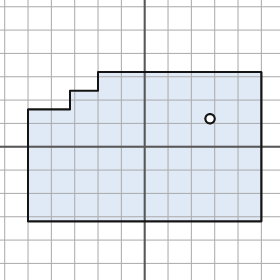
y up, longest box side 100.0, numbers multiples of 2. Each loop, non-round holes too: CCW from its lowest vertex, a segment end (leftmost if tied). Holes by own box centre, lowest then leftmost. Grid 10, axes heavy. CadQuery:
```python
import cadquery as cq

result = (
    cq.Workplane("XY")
    .moveTo(-50.0, -32.0)
    .lineTo(50.0, -32.0)
    .lineTo(50.0, 32.0)
    .lineTo(-20.0, 32.0)
    .lineTo(-20.0, 24.0)
    .lineTo(-32.0, 24.0)
    .lineTo(-32.0, 16.0)
    .lineTo(-50.0, 16.0)
    .close()
    .moveTo(28.0, 12.0)
    .circle(2.0)
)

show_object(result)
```